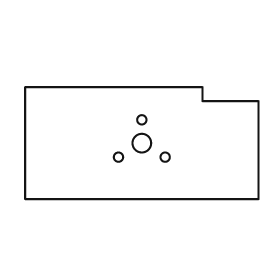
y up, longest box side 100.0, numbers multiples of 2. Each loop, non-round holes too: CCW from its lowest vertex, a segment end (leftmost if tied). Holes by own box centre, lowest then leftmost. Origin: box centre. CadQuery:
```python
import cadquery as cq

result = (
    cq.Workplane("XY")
    .moveTo(-50.0, -24.0)
    .lineTo(50.0, -24.0)
    .lineTo(50.0, 18.0)
    .lineTo(26.0, 18.0)
    .lineTo(26.0, 24.0)
    .lineTo(-50.0, 24.0)
    .close()
    .moveTo(-10.0, -6.0)
    .circle(2.0)
    .moveTo(10.0, -6.0)
    .circle(2.0)
    .moveTo(0.0, 0.0)
    .circle(4.0)
    .moveTo(0.0, 10.0)
    .circle(2.0)
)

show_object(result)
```